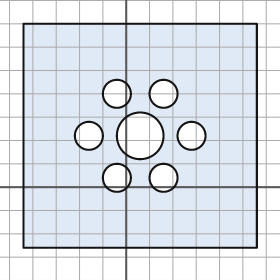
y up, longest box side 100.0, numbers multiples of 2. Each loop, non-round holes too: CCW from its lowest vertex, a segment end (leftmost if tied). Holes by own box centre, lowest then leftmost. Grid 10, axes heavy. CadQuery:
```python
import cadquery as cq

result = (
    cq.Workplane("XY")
    .moveTo(-44.0, -26.0)
    .lineTo(56.0, -26.0)
    .lineTo(56.0, 70.0)
    .lineTo(-44.0, 70.0)
    .close()
    .moveTo(-4.0, 4.0)
    .circle(6.0)
    .moveTo(16.0, 4.0)
    .circle(6.0)
    .moveTo(-16.0, 22.0)
    .circle(6.0)
    .moveTo(6.0, 22.0)
    .circle(10.0)
    .moveTo(28.0, 22.0)
    .circle(6.0)
    .moveTo(-4.0, 40.0)
    .circle(6.0)
    .moveTo(16.0, 40.0)
    .circle(6.0)
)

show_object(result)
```